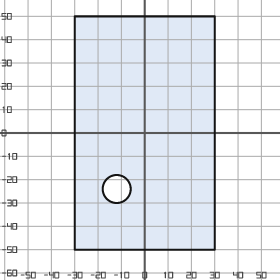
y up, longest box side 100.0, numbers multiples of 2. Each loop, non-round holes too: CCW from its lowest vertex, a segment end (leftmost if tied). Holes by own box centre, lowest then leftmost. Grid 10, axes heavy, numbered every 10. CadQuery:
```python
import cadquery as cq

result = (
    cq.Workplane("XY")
    .moveTo(-30.0, -50.0)
    .lineTo(30.0, -50.0)
    .lineTo(30.0, 50.0)
    .lineTo(-30.0, 50.0)
    .close()
    .moveTo(-12.0, -24.0)
    .circle(6.0)
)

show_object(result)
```